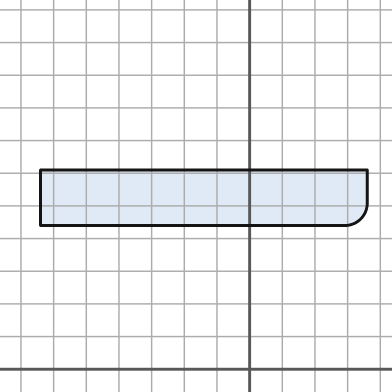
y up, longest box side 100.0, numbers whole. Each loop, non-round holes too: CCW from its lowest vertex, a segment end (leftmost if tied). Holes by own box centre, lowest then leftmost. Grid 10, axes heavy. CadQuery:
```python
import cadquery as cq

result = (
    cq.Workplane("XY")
    .moveTo(-64.0, 44.0)
    .lineTo(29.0, 44.0)
    .threePointArc((34.0, 46.0), (36.0, 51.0))
    .lineTo(36.0, 61.0)
    .lineTo(-64.0, 61.0)
    .close()
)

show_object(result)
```